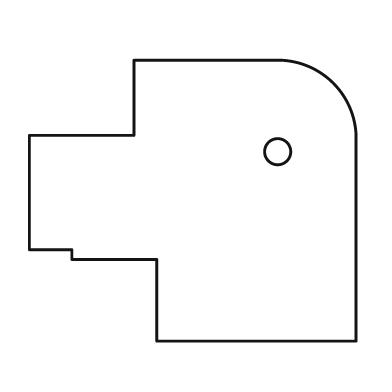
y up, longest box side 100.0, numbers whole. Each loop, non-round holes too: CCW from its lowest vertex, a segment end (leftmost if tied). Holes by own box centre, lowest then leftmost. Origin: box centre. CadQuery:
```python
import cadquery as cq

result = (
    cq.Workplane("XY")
    .moveTo(-11.0, -43.0)
    .lineTo(50.0, -43.0)
    .lineTo(50.0, 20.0)
    .threePointArc((43.0, 36.0), (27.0, 43.0))
    .lineTo(-18.0, 43.0)
    .lineTo(-18.0, 20.0)
    .lineTo(-50.0, 20.0)
    .lineTo(-50.0, -15.0)
    .lineTo(-37.0, -15.0)
    .lineTo(-37.0, -18.0)
    .lineTo(-11.0, -18.0)
    .close()
    .moveTo(26.0, 15.0)
    .circle(4.0)
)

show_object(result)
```